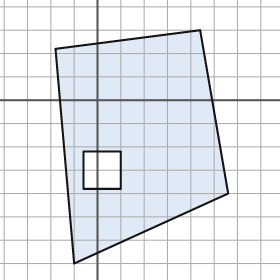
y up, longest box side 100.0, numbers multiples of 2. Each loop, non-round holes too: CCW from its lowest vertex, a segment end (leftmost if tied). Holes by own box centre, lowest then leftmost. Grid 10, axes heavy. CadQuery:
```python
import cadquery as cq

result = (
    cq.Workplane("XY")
    .moveTo(-10.0, -70.0)
    .lineTo(56.0, -40.0)
    .lineTo(44.0, 30.0)
    .lineTo(-18.0, 22.0)
    .close()
    .moveTo(-6.0, -38.0)
    .lineTo(10.0, -38.0)
    .lineTo(10.0, -22.0)
    .lineTo(-6.0, -22.0)
    .close()
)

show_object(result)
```